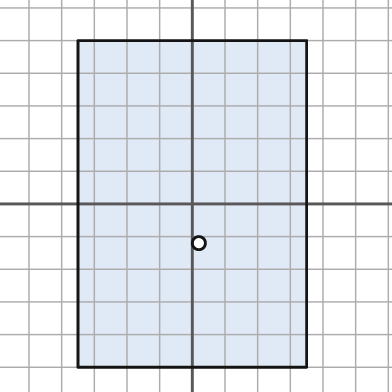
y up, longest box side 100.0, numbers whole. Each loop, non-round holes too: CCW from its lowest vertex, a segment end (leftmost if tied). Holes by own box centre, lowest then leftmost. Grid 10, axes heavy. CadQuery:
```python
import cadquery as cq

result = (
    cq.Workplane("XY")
    .moveTo(-35.0, -50.0)
    .lineTo(35.0, -50.0)
    .lineTo(35.0, 50.0)
    .lineTo(-35.0, 50.0)
    .close()
    .moveTo(2.0, -12.0)
    .circle(2.0)
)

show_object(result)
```